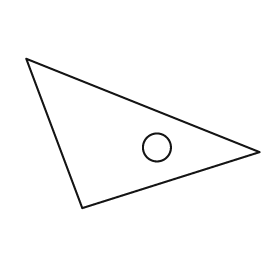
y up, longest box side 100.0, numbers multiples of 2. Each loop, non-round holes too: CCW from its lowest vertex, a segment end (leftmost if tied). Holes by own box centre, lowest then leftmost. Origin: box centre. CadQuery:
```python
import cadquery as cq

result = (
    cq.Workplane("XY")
    .moveTo(-26.0, -32.0)
    .lineTo(50.0, -8.0)
    .lineTo(-50.0, 32.0)
    .close()
    .moveTo(6.0, -6.0)
    .circle(6.0)
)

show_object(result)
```